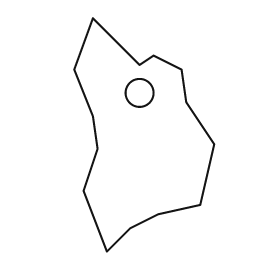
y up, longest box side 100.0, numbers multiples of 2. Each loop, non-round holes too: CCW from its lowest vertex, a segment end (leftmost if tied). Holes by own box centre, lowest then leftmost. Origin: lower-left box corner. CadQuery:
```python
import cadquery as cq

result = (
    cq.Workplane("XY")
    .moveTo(14.0, 0.0)
    .lineTo(24.0, 10.0)
    .lineTo(36.0, 16.0)
    .lineTo(54.0, 20.0)
    .lineTo(60.0, 46.0)
    .lineTo(48.0, 64.0)
    .lineTo(46.0, 78.0)
    .lineTo(34.0, 84.0)
    .lineTo(28.0, 80.0)
    .lineTo(8.0, 100.0)
    .lineTo(0.0, 78.0)
    .lineTo(8.0, 58.0)
    .lineTo(10.0, 44.0)
    .lineTo(4.0, 26.0)
    .close()
    .moveTo(28.0, 68.0)
    .circle(6.0)
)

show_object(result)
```